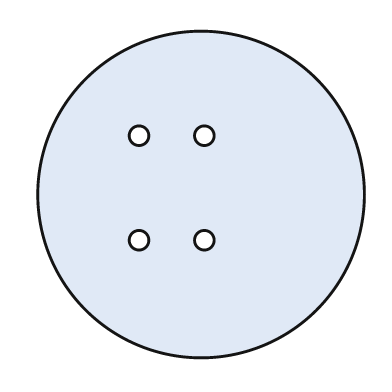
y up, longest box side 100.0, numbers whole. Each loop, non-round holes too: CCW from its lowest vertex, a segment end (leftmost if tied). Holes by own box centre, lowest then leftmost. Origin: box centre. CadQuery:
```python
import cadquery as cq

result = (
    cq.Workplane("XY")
    .moveTo(0.0, 0.0)
    .circle(50.0)
    .moveTo(-19.0, -14.0)
    .circle(3.0)
    .moveTo(1.0, -14.0)
    .circle(3.0)
    .moveTo(-19.0, 18.0)
    .circle(3.0)
    .moveTo(1.0, 18.0)
    .circle(3.0)
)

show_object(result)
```